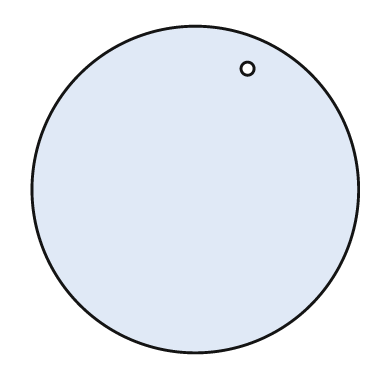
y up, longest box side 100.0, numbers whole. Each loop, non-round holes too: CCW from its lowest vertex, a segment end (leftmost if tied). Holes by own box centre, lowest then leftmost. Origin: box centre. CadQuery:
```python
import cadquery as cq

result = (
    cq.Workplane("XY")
    .moveTo(0.0, 0.0)
    .circle(50.0)
    .moveTo(16.0, 37.0)
    .circle(2.0)
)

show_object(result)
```